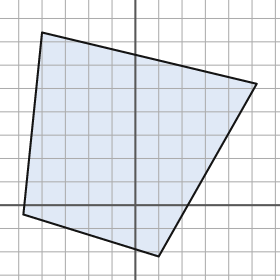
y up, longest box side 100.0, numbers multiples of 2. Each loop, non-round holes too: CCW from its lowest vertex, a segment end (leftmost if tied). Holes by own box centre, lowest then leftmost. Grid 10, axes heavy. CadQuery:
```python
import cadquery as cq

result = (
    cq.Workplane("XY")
    .moveTo(10.0, -22.0)
    .lineTo(52.0, 52.0)
    .lineTo(-40.0, 74.0)
    .lineTo(-48.0, -4.0)
    .close()
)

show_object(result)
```